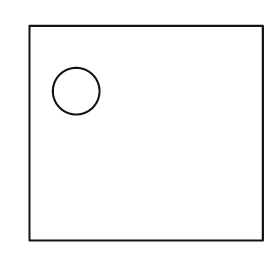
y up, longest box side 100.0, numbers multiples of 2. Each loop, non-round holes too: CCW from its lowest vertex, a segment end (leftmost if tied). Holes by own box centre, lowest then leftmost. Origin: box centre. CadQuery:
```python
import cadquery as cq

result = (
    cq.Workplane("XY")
    .moveTo(-50.0, -46.0)
    .lineTo(50.0, -46.0)
    .lineTo(50.0, 46.0)
    .lineTo(-50.0, 46.0)
    .close()
    .moveTo(-30.0, 18.0)
    .circle(10.0)
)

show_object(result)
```